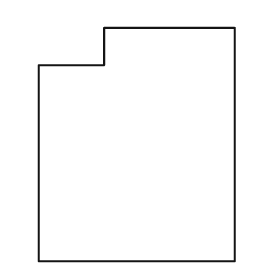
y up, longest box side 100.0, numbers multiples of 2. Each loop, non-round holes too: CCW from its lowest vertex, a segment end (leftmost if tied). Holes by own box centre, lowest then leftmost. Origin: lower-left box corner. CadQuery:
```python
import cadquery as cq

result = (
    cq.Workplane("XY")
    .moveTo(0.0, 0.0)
    .lineTo(84.0, 0.0)
    .lineTo(84.0, 100.0)
    .lineTo(28.0, 100.0)
    .lineTo(28.0, 84.0)
    .lineTo(0.0, 84.0)
    .close()
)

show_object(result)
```